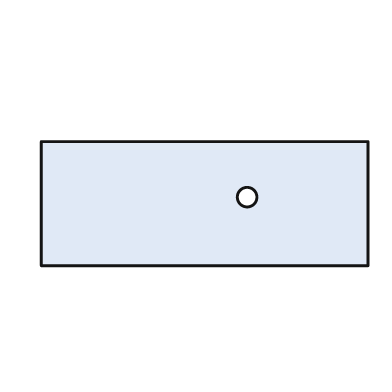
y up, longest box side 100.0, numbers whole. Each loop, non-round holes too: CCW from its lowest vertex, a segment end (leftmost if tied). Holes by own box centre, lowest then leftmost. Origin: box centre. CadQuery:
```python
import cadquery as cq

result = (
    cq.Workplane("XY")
    .moveTo(-50.0, -19.0)
    .lineTo(50.0, -19.0)
    .lineTo(50.0, 19.0)
    .lineTo(-50.0, 19.0)
    .close()
    .moveTo(13.0, 2.0)
    .circle(3.0)
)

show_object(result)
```